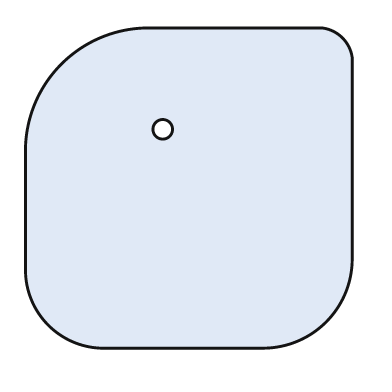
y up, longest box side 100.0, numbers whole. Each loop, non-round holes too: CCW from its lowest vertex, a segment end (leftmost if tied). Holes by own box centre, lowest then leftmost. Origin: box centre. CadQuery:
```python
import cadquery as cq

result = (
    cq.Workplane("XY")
    .moveTo(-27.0, -49.0)
    .lineTo(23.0, -49.0)
    .threePointArc((42.0, -41.0), (50.0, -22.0))
    .lineTo(50.0, 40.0)
    .threePointArc((47.0, 46.0), (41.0, 49.0))
    .lineTo(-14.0, 49.0)
    .threePointArc((-39.0, 38.0), (-50.0, 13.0))
    .lineTo(-50.0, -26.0)
    .threePointArc((-43.0, -42.0), (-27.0, -49.0))
    .close()
    .moveTo(-8.0, 18.0)
    .circle(3.0)
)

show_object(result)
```